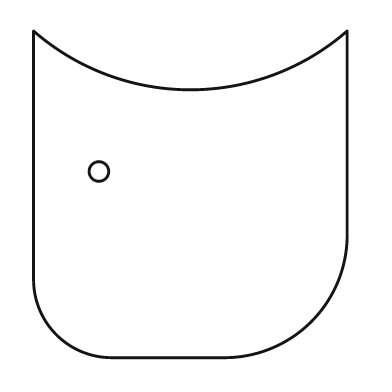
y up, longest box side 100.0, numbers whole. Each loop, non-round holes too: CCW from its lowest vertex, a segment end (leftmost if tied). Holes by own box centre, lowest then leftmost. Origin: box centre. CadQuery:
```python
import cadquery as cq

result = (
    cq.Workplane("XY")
    .moveTo(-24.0, -50.0)
    .lineTo(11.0, -50.0)
    .threePointArc((37.0, -39.0), (48.0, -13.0))
    .lineTo(48.0, 50.0)
    .threePointArc((0.0, 32.0), (-48.0, 50.0))
    .lineTo(-48.0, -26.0)
    .threePointArc((-41.0, -43.0), (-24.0, -50.0))
    .close()
    .moveTo(-28.0, 7.0)
    .circle(3.0)
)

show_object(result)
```